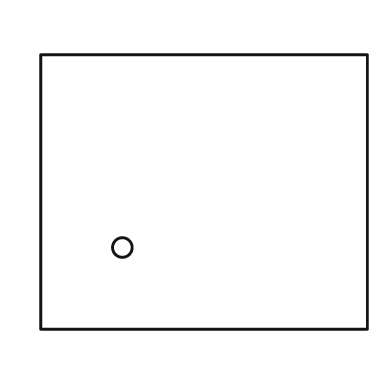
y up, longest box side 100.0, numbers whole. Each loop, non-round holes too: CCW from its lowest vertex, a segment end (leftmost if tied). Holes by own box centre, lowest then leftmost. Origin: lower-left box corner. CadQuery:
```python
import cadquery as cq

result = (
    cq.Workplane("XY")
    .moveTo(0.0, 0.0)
    .lineTo(100.0, 0.0)
    .lineTo(100.0, 84.0)
    .lineTo(0.0, 84.0)
    .close()
    .moveTo(25.0, 25.0)
    .circle(3.0)
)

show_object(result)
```